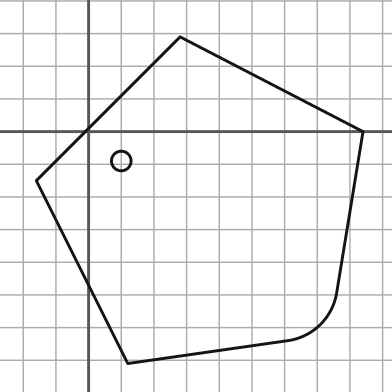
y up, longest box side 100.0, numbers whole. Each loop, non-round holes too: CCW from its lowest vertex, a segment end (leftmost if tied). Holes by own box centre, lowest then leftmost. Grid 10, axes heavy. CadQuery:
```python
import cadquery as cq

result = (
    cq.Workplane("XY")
    .moveTo(12.0, -71.0)
    .lineTo(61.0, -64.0)
    .threePointArc((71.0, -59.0), (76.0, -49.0))
    .lineTo(84.0, 0.0)
    .lineTo(28.0, 29.0)
    .lineTo(-16.0, -15.0)
    .close()
    .moveTo(10.0, -9.0)
    .circle(3.0)
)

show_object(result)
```